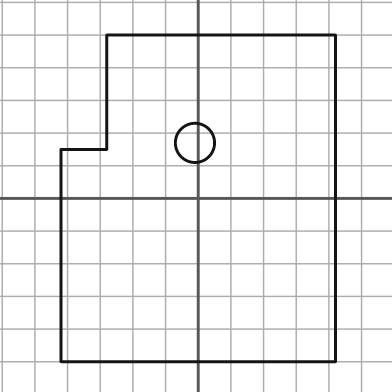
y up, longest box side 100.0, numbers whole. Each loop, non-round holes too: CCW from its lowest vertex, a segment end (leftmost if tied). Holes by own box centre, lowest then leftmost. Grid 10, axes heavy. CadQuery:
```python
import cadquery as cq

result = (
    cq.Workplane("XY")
    .moveTo(-42.0, -50.0)
    .lineTo(42.0, -50.0)
    .lineTo(42.0, 50.0)
    .lineTo(-28.0, 50.0)
    .lineTo(-28.0, 15.0)
    .lineTo(-42.0, 15.0)
    .close()
    .moveTo(-1.0, 17.0)
    .circle(6.0)
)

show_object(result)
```